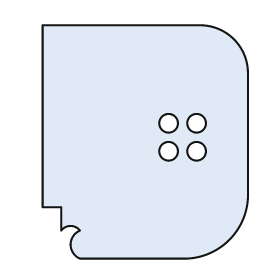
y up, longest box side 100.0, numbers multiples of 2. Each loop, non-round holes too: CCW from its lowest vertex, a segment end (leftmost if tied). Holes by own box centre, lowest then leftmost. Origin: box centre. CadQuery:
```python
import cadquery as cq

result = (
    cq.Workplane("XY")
    .moveTo(-28.0, -50.0)
    .lineTo(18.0, -50.0)
    .threePointArc((36.0, -42.0), (44.0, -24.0))
    .lineTo(44.0, 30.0)
    .threePointArc((38.0, 44.0), (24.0, 50.0))
    .lineTo(-44.0, 50.0)
    .lineTo(-44.0, -28.0)
    .lineTo(-36.0, -28.0)
    .lineTo(-36.0, -38.0)
    .threePointArc((-32.0, -36.0), (-28.0, -38.0))
    .threePointArc((-32.0, -44.0), (-28.0, -50.0))
    .close()
    .moveTo(10.0, -4.0)
    .circle(4.0)
    .moveTo(22.0, -4.0)
    .circle(4.0)
    .moveTo(10.0, 8.0)
    .circle(4.0)
    .moveTo(22.0, 8.0)
    .circle(4.0)
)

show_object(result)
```